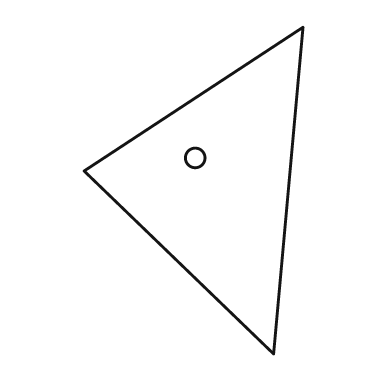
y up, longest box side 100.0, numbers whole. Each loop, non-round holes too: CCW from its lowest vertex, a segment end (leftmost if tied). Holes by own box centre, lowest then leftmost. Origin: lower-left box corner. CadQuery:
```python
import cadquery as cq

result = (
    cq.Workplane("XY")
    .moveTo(58.0, 0.0)
    .lineTo(67.0, 100.0)
    .lineTo(0.0, 56.0)
    .close()
    .moveTo(34.0, 60.0)
    .circle(3.0)
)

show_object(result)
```